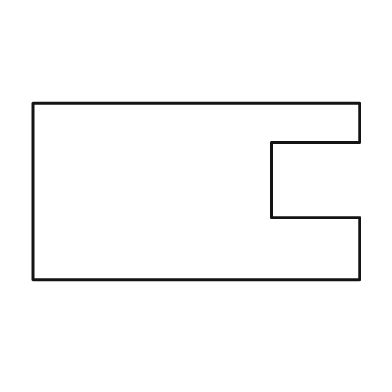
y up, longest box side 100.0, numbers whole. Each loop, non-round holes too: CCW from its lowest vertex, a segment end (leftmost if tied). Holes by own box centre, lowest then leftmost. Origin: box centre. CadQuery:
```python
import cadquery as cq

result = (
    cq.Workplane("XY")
    .moveTo(-50.0, -27.0)
    .lineTo(50.0, -27.0)
    .lineTo(50.0, -8.0)
    .lineTo(23.0, -8.0)
    .lineTo(23.0, 15.0)
    .lineTo(50.0, 15.0)
    .lineTo(50.0, 27.0)
    .lineTo(-50.0, 27.0)
    .close()
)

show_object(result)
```